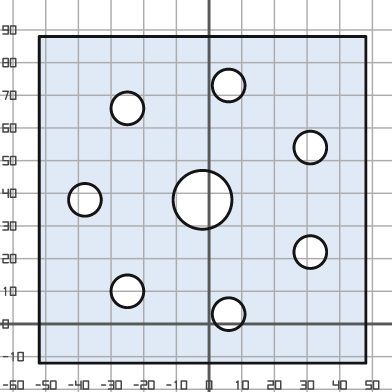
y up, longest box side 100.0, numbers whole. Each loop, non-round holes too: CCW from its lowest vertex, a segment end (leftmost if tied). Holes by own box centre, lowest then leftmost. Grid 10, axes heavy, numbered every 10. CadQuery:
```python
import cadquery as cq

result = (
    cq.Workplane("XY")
    .moveTo(-52.0, -12.0)
    .lineTo(48.0, -12.0)
    .lineTo(48.0, 88.0)
    .lineTo(-52.0, 88.0)
    .close()
    .moveTo(6.0, 3.0)
    .circle(5.0)
    .moveTo(-25.0, 10.0)
    .circle(5.0)
    .moveTo(31.0, 22.0)
    .circle(5.0)
    .moveTo(-38.0, 38.0)
    .circle(5.0)
    .moveTo(-2.0, 38.0)
    .circle(9.0)
    .moveTo(31.0, 54.0)
    .circle(5.0)
    .moveTo(-25.0, 66.0)
    .circle(5.0)
    .moveTo(6.0, 73.0)
    .circle(5.0)
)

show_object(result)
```